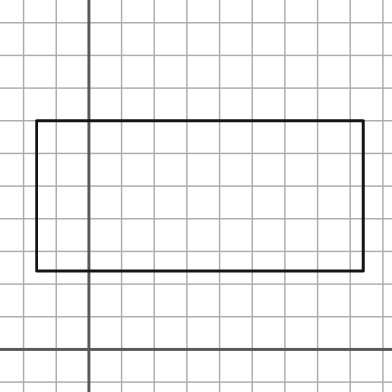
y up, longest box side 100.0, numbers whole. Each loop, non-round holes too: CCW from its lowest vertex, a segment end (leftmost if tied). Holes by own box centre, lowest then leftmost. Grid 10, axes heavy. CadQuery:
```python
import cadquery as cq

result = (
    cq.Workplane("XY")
    .moveTo(-16.0, 24.0)
    .lineTo(84.0, 24.0)
    .lineTo(84.0, 70.0)
    .lineTo(-16.0, 70.0)
    .close()
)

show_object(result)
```